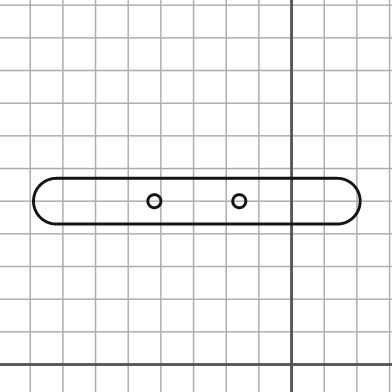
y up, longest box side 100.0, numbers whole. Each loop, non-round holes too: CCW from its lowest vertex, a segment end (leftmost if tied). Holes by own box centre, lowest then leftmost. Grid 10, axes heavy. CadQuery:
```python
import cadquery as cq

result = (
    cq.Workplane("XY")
    .moveTo(-72.0, 43.0)
    .lineTo(14.0, 43.0)
    .threePointArc((21.0, 50.0), (14.0, 57.0))
    .lineTo(-72.0, 57.0)
    .threePointArc((-79.0, 50.0), (-72.0, 43.0))
    .close()
    .moveTo(-42.0, 50.0)
    .circle(2.0)
    .moveTo(-16.0, 50.0)
    .circle(2.0)
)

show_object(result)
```